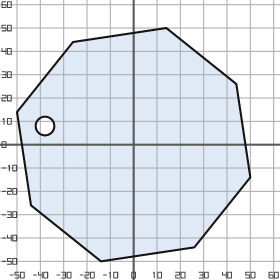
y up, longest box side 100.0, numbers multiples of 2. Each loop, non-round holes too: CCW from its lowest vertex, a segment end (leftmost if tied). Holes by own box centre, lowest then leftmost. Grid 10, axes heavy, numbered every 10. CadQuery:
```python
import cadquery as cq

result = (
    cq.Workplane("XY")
    .moveTo(-14.0, -50.0)
    .lineTo(26.0, -44.0)
    .lineTo(50.0, -14.0)
    .lineTo(44.0, 26.0)
    .lineTo(14.0, 50.0)
    .lineTo(-26.0, 44.0)
    .lineTo(-50.0, 14.0)
    .lineTo(-44.0, -26.0)
    .close()
    .moveTo(-38.0, 8.0)
    .circle(4.0)
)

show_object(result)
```